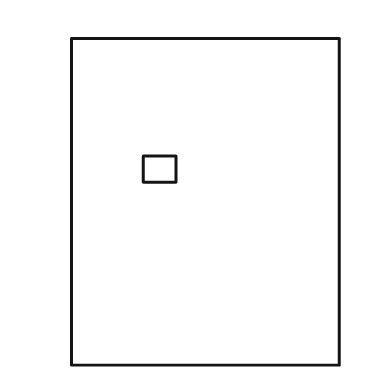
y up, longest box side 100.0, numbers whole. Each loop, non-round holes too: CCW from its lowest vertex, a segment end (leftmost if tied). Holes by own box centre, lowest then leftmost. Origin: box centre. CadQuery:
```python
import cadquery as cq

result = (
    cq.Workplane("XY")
    .moveTo(-41.0, -50.0)
    .lineTo(41.0, -50.0)
    .lineTo(41.0, 50.0)
    .lineTo(-41.0, 50.0)
    .close()
    .moveTo(-19.0, 6.0)
    .lineTo(-9.0, 6.0)
    .lineTo(-9.0, 14.0)
    .lineTo(-19.0, 14.0)
    .close()
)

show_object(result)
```